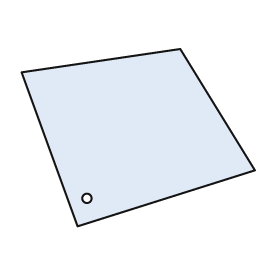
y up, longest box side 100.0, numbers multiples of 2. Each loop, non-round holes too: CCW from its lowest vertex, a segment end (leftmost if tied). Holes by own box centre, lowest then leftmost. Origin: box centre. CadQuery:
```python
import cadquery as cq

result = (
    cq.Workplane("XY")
    .moveTo(-26.0, -38.0)
    .lineTo(50.0, -14.0)
    .lineTo(18.0, 38.0)
    .lineTo(-50.0, 28.0)
    .close()
    .moveTo(-22.0, -26.0)
    .circle(2.0)
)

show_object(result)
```